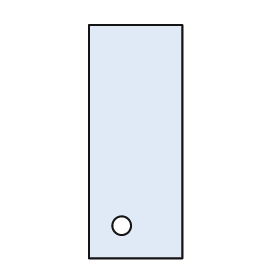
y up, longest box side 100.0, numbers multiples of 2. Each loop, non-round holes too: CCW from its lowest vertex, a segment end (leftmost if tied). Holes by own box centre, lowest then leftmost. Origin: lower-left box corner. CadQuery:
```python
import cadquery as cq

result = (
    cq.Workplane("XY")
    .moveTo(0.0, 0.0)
    .lineTo(40.0, 0.0)
    .lineTo(40.0, 100.0)
    .lineTo(0.0, 100.0)
    .close()
    .moveTo(14.0, 14.0)
    .circle(4.0)
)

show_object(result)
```